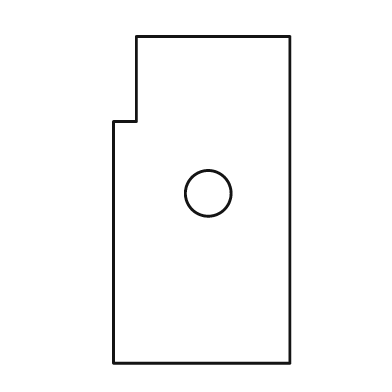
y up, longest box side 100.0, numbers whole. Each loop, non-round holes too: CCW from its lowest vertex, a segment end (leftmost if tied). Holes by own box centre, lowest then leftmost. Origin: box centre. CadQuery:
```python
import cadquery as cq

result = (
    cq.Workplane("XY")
    .moveTo(-27.0, -50.0)
    .lineTo(27.0, -50.0)
    .lineTo(27.0, 50.0)
    .lineTo(-20.0, 50.0)
    .lineTo(-20.0, 24.0)
    .lineTo(-27.0, 24.0)
    .close()
    .moveTo(2.0, 2.0)
    .circle(7.0)
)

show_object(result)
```